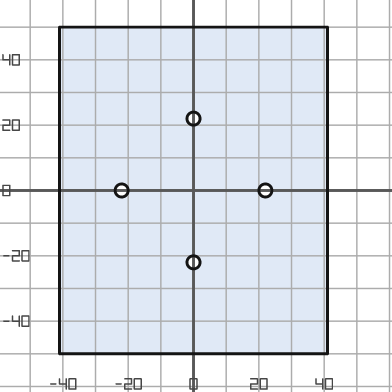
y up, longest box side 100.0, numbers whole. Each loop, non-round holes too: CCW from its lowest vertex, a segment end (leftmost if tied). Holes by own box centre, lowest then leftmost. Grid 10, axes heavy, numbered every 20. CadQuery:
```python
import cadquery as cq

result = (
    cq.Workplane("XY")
    .moveTo(-41.0, -50.0)
    .lineTo(41.0, -50.0)
    .lineTo(41.0, 50.0)
    .lineTo(-41.0, 50.0)
    .close()
    .moveTo(0.0, -22.0)
    .circle(2.0)
    .moveTo(-22.0, 0.0)
    .circle(2.0)
    .moveTo(22.0, 0.0)
    .circle(2.0)
    .moveTo(0.0, 22.0)
    .circle(2.0)
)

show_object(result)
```